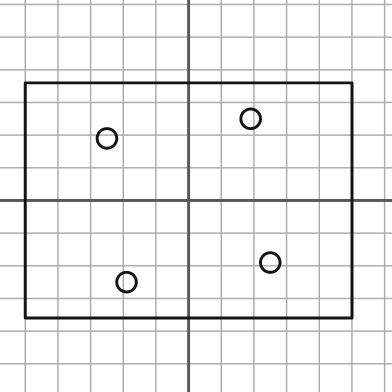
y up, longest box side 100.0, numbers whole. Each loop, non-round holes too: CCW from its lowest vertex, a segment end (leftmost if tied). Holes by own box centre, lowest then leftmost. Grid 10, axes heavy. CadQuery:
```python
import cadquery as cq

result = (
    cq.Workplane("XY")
    .moveTo(-50.0, -36.0)
    .lineTo(50.0, -36.0)
    .lineTo(50.0, 36.0)
    .lineTo(-50.0, 36.0)
    .close()
    .moveTo(-19.0, -25.0)
    .circle(3.0)
    .moveTo(25.0, -19.0)
    .circle(3.0)
    .moveTo(-25.0, 19.0)
    .circle(3.0)
    .moveTo(19.0, 25.0)
    .circle(3.0)
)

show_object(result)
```